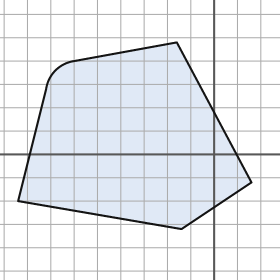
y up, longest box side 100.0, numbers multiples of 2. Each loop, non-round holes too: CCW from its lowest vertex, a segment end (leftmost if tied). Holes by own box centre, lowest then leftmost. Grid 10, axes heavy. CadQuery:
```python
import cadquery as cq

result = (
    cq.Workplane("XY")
    .moveTo(-14.0, -32.0)
    .lineTo(16.0, -12.0)
    .lineTo(-16.0, 48.0)
    .lineTo(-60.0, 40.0)
    .threePointArc((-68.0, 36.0), (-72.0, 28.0))
    .lineTo(-84.0, -20.0)
    .close()
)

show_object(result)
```